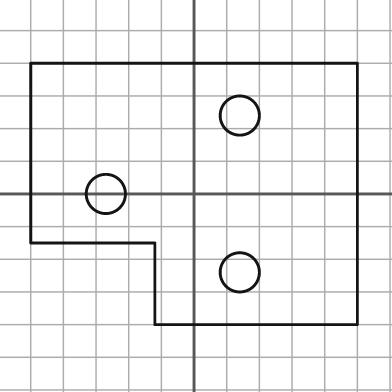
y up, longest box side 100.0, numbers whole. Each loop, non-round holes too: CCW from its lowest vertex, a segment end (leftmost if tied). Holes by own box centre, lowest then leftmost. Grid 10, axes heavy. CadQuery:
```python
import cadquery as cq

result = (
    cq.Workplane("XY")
    .moveTo(-12.0, -40.0)
    .lineTo(50.0, -40.0)
    .lineTo(50.0, 40.0)
    .lineTo(-50.0, 40.0)
    .lineTo(-50.0, -15.0)
    .lineTo(-12.0, -15.0)
    .close()
    .moveTo(14.0, -24.0)
    .circle(6.0)
    .moveTo(-27.0, 0.0)
    .circle(6.0)
    .moveTo(14.0, 24.0)
    .circle(6.0)
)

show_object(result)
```